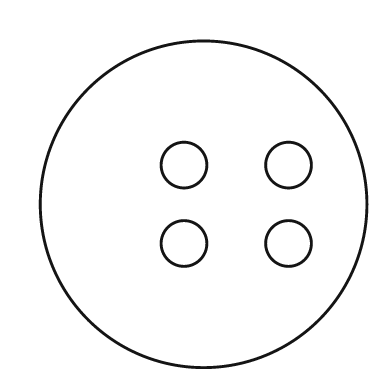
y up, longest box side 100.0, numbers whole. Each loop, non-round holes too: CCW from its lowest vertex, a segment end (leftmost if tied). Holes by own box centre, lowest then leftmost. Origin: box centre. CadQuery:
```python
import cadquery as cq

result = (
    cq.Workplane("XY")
    .moveTo(0.0, 0.0)
    .circle(50.0)
    .moveTo(-6.0, -12.0)
    .circle(7.0)
    .moveTo(26.0, -12.0)
    .circle(7.0)
    .moveTo(-6.0, 12.0)
    .circle(7.0)
    .moveTo(26.0, 12.0)
    .circle(7.0)
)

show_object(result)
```